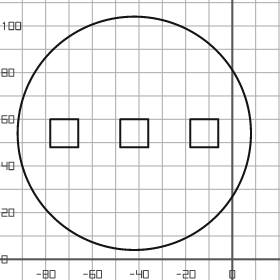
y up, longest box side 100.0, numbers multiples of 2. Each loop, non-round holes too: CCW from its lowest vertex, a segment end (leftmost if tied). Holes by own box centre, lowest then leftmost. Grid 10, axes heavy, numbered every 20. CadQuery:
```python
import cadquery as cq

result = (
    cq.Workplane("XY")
    .moveTo(-42.0, 54.0)
    .circle(50.0)
    .moveTo(-78.0, 48.0)
    .lineTo(-66.0, 48.0)
    .lineTo(-66.0, 60.0)
    .lineTo(-78.0, 60.0)
    .close()
    .moveTo(-48.0, 48.0)
    .lineTo(-36.0, 48.0)
    .lineTo(-36.0, 60.0)
    .lineTo(-48.0, 60.0)
    .close()
    .moveTo(-18.0, 48.0)
    .lineTo(-6.0, 48.0)
    .lineTo(-6.0, 60.0)
    .lineTo(-18.0, 60.0)
    .close()
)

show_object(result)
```